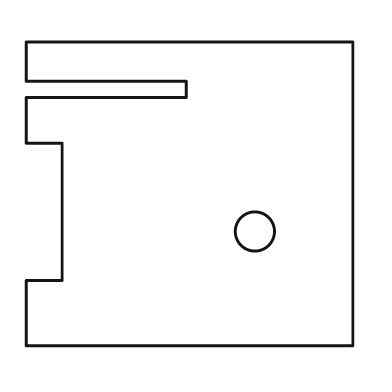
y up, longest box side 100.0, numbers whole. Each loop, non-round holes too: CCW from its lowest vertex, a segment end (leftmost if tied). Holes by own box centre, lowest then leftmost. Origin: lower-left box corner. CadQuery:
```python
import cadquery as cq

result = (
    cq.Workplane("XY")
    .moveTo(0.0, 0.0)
    .lineTo(100.0, 0.0)
    .lineTo(100.0, 93.0)
    .lineTo(0.0, 93.0)
    .lineTo(0.0, 81.0)
    .lineTo(49.0, 81.0)
    .lineTo(49.0, 76.0)
    .lineTo(0.0, 76.0)
    .lineTo(0.0, 62.0)
    .lineTo(11.0, 62.0)
    .lineTo(11.0, 20.0)
    .lineTo(0.0, 20.0)
    .close()
    .moveTo(70.0, 35.0)
    .circle(6.0)
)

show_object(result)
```